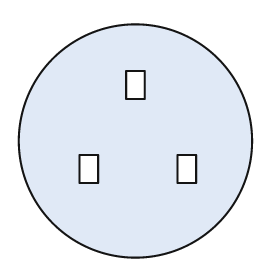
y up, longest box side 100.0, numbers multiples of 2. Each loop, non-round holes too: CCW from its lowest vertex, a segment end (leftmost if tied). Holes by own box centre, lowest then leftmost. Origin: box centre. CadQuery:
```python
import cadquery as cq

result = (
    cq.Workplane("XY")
    .moveTo(0.0, 0.0)
    .circle(50.0)
    .moveTo(-24.0, -18.0)
    .lineTo(-16.0, -18.0)
    .lineTo(-16.0, -6.0)
    .lineTo(-24.0, -6.0)
    .close()
    .moveTo(18.0, -18.0)
    .lineTo(26.0, -18.0)
    .lineTo(26.0, -6.0)
    .lineTo(18.0, -6.0)
    .close()
    .moveTo(-4.0, 18.0)
    .lineTo(4.0, 18.0)
    .lineTo(4.0, 30.0)
    .lineTo(-4.0, 30.0)
    .close()
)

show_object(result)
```